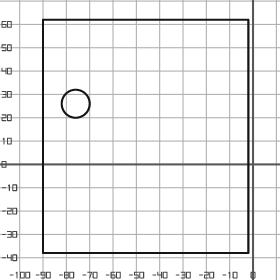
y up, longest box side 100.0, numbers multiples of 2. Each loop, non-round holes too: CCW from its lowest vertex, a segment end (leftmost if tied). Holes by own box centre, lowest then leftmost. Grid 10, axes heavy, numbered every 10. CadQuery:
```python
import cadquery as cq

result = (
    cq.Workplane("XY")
    .moveTo(-90.0, -38.0)
    .lineTo(-2.0, -38.0)
    .lineTo(-2.0, 62.0)
    .lineTo(-90.0, 62.0)
    .close()
    .moveTo(-76.0, 26.0)
    .circle(6.0)
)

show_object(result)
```